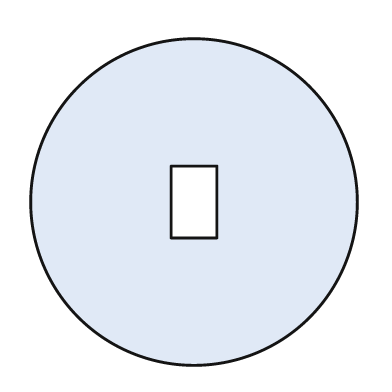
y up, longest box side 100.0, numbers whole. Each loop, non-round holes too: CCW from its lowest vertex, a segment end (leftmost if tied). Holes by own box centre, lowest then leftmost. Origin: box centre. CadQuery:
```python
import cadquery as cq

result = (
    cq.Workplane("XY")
    .moveTo(0.0, 0.0)
    .circle(50.0)
    .moveTo(-7.0, -11.0)
    .lineTo(7.0, -11.0)
    .lineTo(7.0, 11.0)
    .lineTo(-7.0, 11.0)
    .close()
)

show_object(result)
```